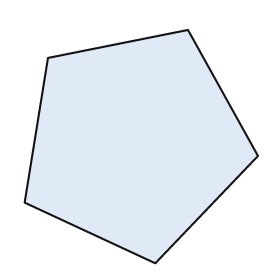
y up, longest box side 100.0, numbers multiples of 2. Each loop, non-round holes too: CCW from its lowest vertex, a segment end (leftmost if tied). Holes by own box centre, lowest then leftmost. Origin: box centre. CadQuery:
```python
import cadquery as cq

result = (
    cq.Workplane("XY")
    .moveTo(6.0, -50.0)
    .lineTo(50.0, -4.0)
    .lineTo(20.0, 50.0)
    .lineTo(-40.0, 38.0)
    .lineTo(-50.0, -24.0)
    .close()
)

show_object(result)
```